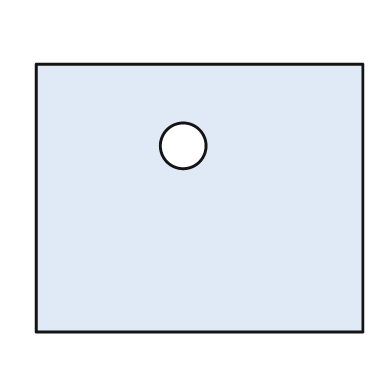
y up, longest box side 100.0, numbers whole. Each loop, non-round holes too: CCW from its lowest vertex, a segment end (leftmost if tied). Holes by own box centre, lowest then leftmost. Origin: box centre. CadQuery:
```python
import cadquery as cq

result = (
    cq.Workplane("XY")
    .moveTo(-50.0, -41.0)
    .lineTo(50.0, -41.0)
    .lineTo(50.0, 41.0)
    .lineTo(-50.0, 41.0)
    .close()
    .moveTo(-5.0, 16.0)
    .circle(7.0)
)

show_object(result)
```